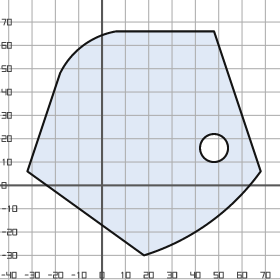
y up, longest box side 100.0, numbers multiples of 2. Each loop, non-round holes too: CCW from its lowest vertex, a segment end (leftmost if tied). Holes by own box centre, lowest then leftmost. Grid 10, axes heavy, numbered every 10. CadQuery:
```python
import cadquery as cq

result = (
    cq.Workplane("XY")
    .moveTo(18.0, -30.0)
    .threePointArc((46.0, -16.0), (68.0, 6.0))
    .lineTo(48.0, 66.0)
    .lineTo(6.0, 66.0)
    .threePointArc((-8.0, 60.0), (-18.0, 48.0))
    .lineTo(-32.0, 6.0)
    .close()
    .moveTo(48.0, 16.0)
    .circle(6.0)
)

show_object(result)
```